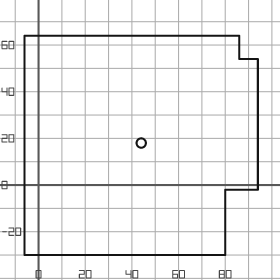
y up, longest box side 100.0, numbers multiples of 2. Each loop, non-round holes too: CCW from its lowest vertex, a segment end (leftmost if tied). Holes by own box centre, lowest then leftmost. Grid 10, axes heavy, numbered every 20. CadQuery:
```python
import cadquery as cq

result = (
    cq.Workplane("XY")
    .moveTo(-6.0, -30.0)
    .lineTo(80.0, -30.0)
    .lineTo(80.0, -2.0)
    .lineTo(94.0, -2.0)
    .lineTo(94.0, 54.0)
    .lineTo(86.0, 54.0)
    .lineTo(86.0, 64.0)
    .lineTo(-6.0, 64.0)
    .close()
    .moveTo(44.0, 18.0)
    .circle(2.0)
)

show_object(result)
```